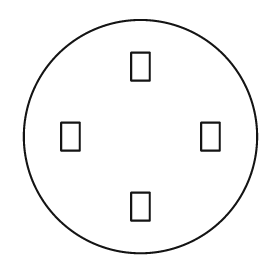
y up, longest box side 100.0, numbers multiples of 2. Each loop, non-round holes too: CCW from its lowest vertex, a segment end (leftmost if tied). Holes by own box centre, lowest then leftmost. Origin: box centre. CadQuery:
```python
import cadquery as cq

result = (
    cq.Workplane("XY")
    .moveTo(0.0, 0.0)
    .circle(50.0)
    .moveTo(-4.0, -36.0)
    .lineTo(4.0, -36.0)
    .lineTo(4.0, -24.0)
    .lineTo(-4.0, -24.0)
    .close()
    .moveTo(-34.0, -6.0)
    .lineTo(-26.0, -6.0)
    .lineTo(-26.0, 6.0)
    .lineTo(-34.0, 6.0)
    .close()
    .moveTo(26.0, -6.0)
    .lineTo(34.0, -6.0)
    .lineTo(34.0, 6.0)
    .lineTo(26.0, 6.0)
    .close()
    .moveTo(-4.0, 24.0)
    .lineTo(4.0, 24.0)
    .lineTo(4.0, 36.0)
    .lineTo(-4.0, 36.0)
    .close()
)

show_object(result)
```